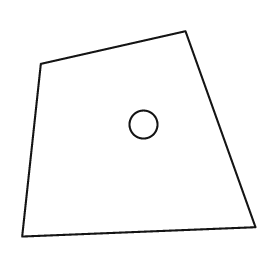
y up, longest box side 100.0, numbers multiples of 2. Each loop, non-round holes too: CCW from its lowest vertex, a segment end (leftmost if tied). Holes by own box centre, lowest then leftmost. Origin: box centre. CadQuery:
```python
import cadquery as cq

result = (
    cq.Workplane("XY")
    .moveTo(-50.0, -44.0)
    .lineTo(50.0, -40.0)
    .lineTo(20.0, 44.0)
    .lineTo(-42.0, 30.0)
    .close()
    .moveTo(2.0, 4.0)
    .circle(6.0)
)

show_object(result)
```